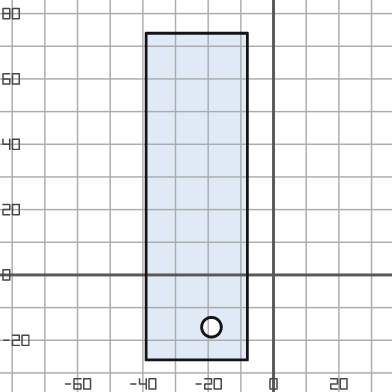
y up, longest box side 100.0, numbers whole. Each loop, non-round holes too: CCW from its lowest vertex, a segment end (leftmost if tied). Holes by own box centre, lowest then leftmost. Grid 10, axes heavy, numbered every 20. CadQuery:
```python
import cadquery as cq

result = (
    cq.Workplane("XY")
    .moveTo(-39.0, -26.0)
    .lineTo(-8.0, -26.0)
    .lineTo(-8.0, 74.0)
    .lineTo(-39.0, 74.0)
    .close()
    .moveTo(-19.0, -16.0)
    .circle(3.0)
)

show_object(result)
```